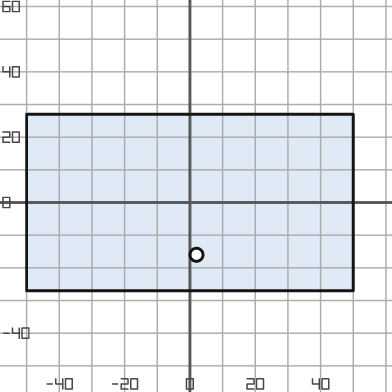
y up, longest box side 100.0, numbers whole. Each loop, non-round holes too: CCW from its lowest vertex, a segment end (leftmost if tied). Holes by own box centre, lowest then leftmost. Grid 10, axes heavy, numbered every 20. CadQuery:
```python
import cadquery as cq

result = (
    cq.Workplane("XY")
    .moveTo(-50.0, -27.0)
    .lineTo(50.0, -27.0)
    .lineTo(50.0, 27.0)
    .lineTo(-50.0, 27.0)
    .close()
    .moveTo(2.0, -16.0)
    .circle(2.0)
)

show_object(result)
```